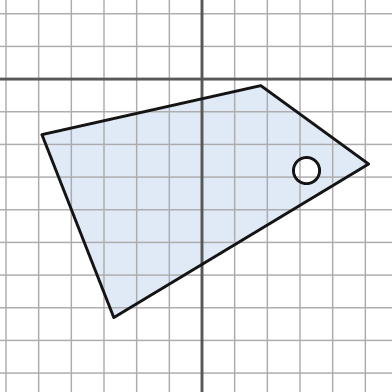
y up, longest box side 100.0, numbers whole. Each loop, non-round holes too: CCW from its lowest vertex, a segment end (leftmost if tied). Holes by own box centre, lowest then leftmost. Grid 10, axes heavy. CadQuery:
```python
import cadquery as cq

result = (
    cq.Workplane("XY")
    .moveTo(-27.0, -73.0)
    .lineTo(51.0, -26.0)
    .lineTo(18.0, -2.0)
    .lineTo(-49.0, -17.0)
    .close()
    .moveTo(32.0, -28.0)
    .circle(4.0)
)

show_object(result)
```